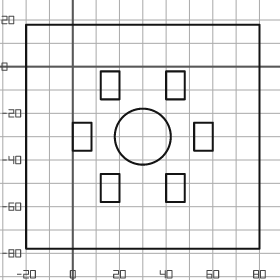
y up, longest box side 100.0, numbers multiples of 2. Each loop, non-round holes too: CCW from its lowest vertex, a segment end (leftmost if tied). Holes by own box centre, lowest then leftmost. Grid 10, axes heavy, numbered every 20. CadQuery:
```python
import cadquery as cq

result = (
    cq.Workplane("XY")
    .moveTo(-20.0, -78.0)
    .lineTo(80.0, -78.0)
    .lineTo(80.0, 18.0)
    .lineTo(-20.0, 18.0)
    .close()
    .moveTo(12.0, -58.0)
    .lineTo(20.0, -58.0)
    .lineTo(20.0, -46.0)
    .lineTo(12.0, -46.0)
    .close()
    .moveTo(40.0, -58.0)
    .lineTo(48.0, -58.0)
    .lineTo(48.0, -46.0)
    .lineTo(40.0, -46.0)
    .close()
    .moveTo(0.0, -36.0)
    .lineTo(8.0, -36.0)
    .lineTo(8.0, -24.0)
    .lineTo(0.0, -24.0)
    .close()
    .moveTo(30.0, -30.0)
    .circle(12.0)
    .moveTo(52.0, -36.0)
    .lineTo(60.0, -36.0)
    .lineTo(60.0, -24.0)
    .lineTo(52.0, -24.0)
    .close()
    .moveTo(12.0, -14.0)
    .lineTo(20.0, -14.0)
    .lineTo(20.0, -2.0)
    .lineTo(12.0, -2.0)
    .close()
    .moveTo(40.0, -14.0)
    .lineTo(48.0, -14.0)
    .lineTo(48.0, -2.0)
    .lineTo(40.0, -2.0)
    .close()
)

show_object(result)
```